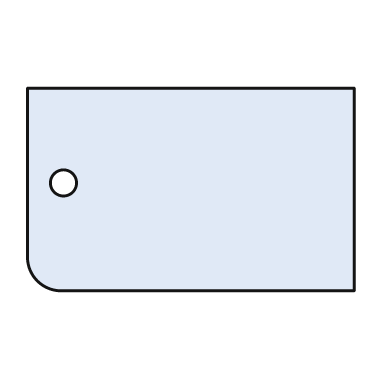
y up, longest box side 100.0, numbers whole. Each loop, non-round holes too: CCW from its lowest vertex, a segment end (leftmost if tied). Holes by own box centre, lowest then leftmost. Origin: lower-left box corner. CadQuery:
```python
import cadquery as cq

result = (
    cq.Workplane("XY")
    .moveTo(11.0, 0.0)
    .lineTo(100.0, 0.0)
    .lineTo(100.0, 62.0)
    .lineTo(0.0, 62.0)
    .lineTo(0.0, 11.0)
    .threePointArc((3.0, 3.0), (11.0, 0.0))
    .close()
    .moveTo(11.0, 33.0)
    .circle(4.0)
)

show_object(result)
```